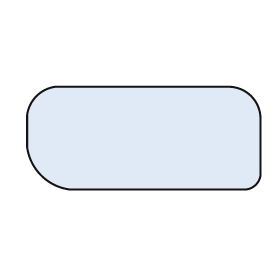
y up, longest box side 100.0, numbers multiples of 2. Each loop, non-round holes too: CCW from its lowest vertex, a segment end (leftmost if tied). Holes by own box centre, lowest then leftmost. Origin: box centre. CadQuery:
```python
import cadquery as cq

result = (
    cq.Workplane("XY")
    .moveTo(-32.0, -22.0)
    .lineTo(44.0, -22.0)
    .threePointArc((48.0, -20.0), (50.0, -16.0))
    .lineTo(50.0, 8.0)
    .threePointArc((46.0, 18.0), (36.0, 22.0))
    .lineTo(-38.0, 22.0)
    .threePointArc((-46.0, 18.0), (-50.0, 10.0))
    .lineTo(-50.0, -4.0)
    .threePointArc((-44.0, -16.0), (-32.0, -22.0))
    .close()
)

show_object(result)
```